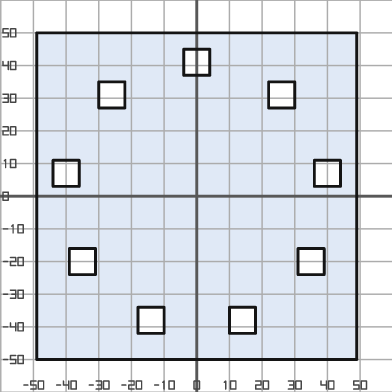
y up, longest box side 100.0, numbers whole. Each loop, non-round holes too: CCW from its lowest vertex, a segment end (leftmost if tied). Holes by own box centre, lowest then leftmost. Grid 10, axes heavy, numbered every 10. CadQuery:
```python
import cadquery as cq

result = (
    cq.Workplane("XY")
    .moveTo(-49.0, -50.0)
    .lineTo(49.0, -50.0)
    .lineTo(49.0, 50.0)
    .lineTo(-49.0, 50.0)
    .close()
    .moveTo(-18.0, -42.0)
    .lineTo(-10.0, -42.0)
    .lineTo(-10.0, -34.0)
    .lineTo(-18.0, -34.0)
    .close()
    .moveTo(10.0, -42.0)
    .lineTo(18.0, -42.0)
    .lineTo(18.0, -34.0)
    .lineTo(10.0, -34.0)
    .close()
    .moveTo(-39.0, -24.0)
    .lineTo(-31.0, -24.0)
    .lineTo(-31.0, -16.0)
    .lineTo(-39.0, -16.0)
    .close()
    .moveTo(31.0, -24.0)
    .lineTo(39.0, -24.0)
    .lineTo(39.0, -16.0)
    .lineTo(31.0, -16.0)
    .close()
    .moveTo(-44.0, 3.0)
    .lineTo(-36.0, 3.0)
    .lineTo(-36.0, 11.0)
    .lineTo(-44.0, 11.0)
    .close()
    .moveTo(36.0, 3.0)
    .lineTo(44.0, 3.0)
    .lineTo(44.0, 11.0)
    .lineTo(36.0, 11.0)
    .close()
    .moveTo(-30.0, 27.0)
    .lineTo(-22.0, 27.0)
    .lineTo(-22.0, 35.0)
    .lineTo(-30.0, 35.0)
    .close()
    .moveTo(22.0, 27.0)
    .lineTo(30.0, 27.0)
    .lineTo(30.0, 35.0)
    .lineTo(22.0, 35.0)
    .close()
    .moveTo(-4.0, 37.0)
    .lineTo(4.0, 37.0)
    .lineTo(4.0, 45.0)
    .lineTo(-4.0, 45.0)
    .close()
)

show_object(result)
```